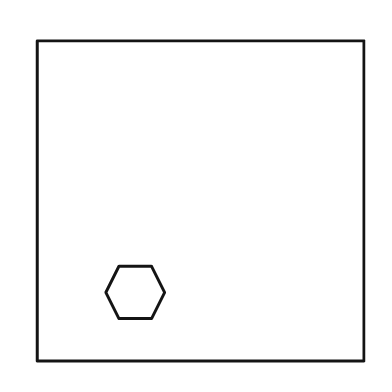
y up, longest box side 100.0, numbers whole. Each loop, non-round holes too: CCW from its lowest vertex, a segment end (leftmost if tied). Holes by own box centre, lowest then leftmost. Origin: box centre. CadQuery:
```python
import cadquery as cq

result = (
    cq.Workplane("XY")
    .moveTo(-50.0, -49.0)
    .lineTo(50.0, -49.0)
    .lineTo(50.0, 49.0)
    .lineTo(-50.0, 49.0)
    .close()
    .moveTo(-25.0, -36.0)
    .lineTo(-15.0, -36.0)
    .lineTo(-11.0, -28.0)
    .lineTo(-15.0, -20.0)
    .lineTo(-25.0, -20.0)
    .lineTo(-29.0, -28.0)
    .close()
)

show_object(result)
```